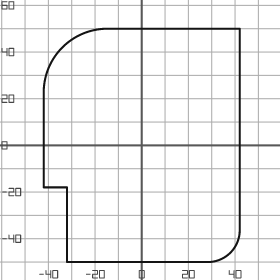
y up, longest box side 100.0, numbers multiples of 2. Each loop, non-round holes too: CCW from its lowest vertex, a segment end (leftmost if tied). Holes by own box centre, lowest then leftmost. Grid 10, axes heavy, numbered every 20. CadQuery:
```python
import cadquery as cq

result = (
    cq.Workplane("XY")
    .moveTo(-32.0, -50.0)
    .lineTo(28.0, -50.0)
    .threePointArc((38.0, -46.0), (42.0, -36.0))
    .lineTo(42.0, 50.0)
    .lineTo(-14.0, 50.0)
    .threePointArc((-34.0, 42.0), (-42.0, 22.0))
    .lineTo(-42.0, -18.0)
    .lineTo(-32.0, -18.0)
    .close()
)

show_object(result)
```